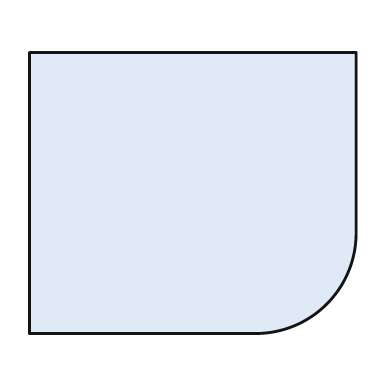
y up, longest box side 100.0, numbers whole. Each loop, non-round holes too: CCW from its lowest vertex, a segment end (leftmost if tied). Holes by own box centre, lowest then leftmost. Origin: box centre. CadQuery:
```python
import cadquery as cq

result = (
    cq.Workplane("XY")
    .moveTo(-50.0, -43.0)
    .lineTo(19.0, -43.0)
    .threePointArc((41.0, -34.0), (50.0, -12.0))
    .lineTo(50.0, 43.0)
    .lineTo(-50.0, 43.0)
    .close()
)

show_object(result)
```